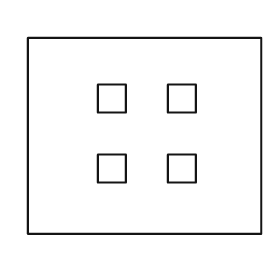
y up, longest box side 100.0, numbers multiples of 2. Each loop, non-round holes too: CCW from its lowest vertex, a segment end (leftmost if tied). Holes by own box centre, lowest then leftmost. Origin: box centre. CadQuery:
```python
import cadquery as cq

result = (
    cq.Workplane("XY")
    .moveTo(-50.0, -42.0)
    .lineTo(50.0, -42.0)
    .lineTo(50.0, 42.0)
    .lineTo(-50.0, 42.0)
    .close()
    .moveTo(-20.0, -20.0)
    .lineTo(-8.0, -20.0)
    .lineTo(-8.0, -8.0)
    .lineTo(-20.0, -8.0)
    .close()
    .moveTo(10.0, -20.0)
    .lineTo(22.0, -20.0)
    .lineTo(22.0, -8.0)
    .lineTo(10.0, -8.0)
    .close()
    .moveTo(-20.0, 10.0)
    .lineTo(-8.0, 10.0)
    .lineTo(-8.0, 22.0)
    .lineTo(-20.0, 22.0)
    .close()
    .moveTo(10.0, 10.0)
    .lineTo(22.0, 10.0)
    .lineTo(22.0, 22.0)
    .lineTo(10.0, 22.0)
    .close()
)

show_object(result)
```